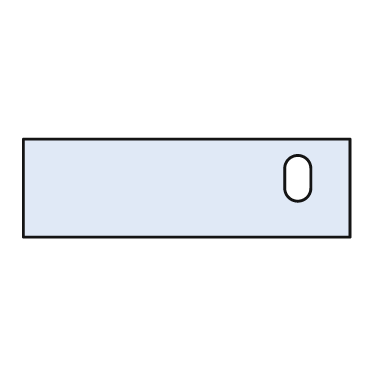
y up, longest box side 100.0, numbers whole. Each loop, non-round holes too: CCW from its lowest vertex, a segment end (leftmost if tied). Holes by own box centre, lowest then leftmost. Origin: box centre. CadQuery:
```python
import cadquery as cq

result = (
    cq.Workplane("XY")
    .moveTo(-50.0, -15.0)
    .lineTo(50.0, -15.0)
    .lineTo(50.0, 15.0)
    .lineTo(-50.0, 15.0)
    .close()
    .moveTo(30.0, 0.0)
    .threePointArc((34.0, -4.0), (38.0, 0.0))
    .lineTo(38.0, 6.0)
    .threePointArc((34.0, 10.0), (30.0, 6.0))
    .close()
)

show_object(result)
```